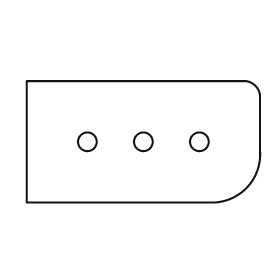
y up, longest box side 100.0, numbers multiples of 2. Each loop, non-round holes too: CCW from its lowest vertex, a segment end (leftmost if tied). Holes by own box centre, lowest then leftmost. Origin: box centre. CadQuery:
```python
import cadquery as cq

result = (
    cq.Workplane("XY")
    .moveTo(-50.0, -26.0)
    .lineTo(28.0, -26.0)
    .threePointArc((44.0, -20.0), (50.0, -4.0))
    .lineTo(50.0, 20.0)
    .threePointArc((48.0, 24.0), (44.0, 26.0))
    .lineTo(-50.0, 26.0)
    .close()
    .moveTo(-24.0, 0.0)
    .circle(4.0)
    .moveTo(0.0, 0.0)
    .circle(4.0)
    .moveTo(24.0, 0.0)
    .circle(4.0)
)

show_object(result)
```